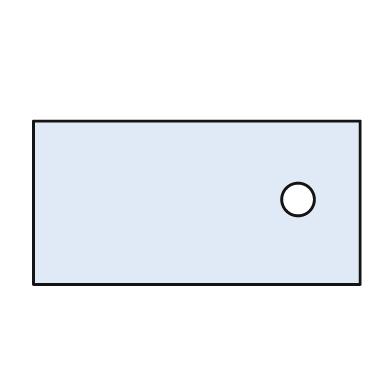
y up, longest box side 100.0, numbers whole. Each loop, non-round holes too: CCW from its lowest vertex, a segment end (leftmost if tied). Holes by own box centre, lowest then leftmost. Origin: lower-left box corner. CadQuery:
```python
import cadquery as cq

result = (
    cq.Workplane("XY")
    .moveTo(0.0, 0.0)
    .lineTo(100.0, 0.0)
    .lineTo(100.0, 50.0)
    .lineTo(0.0, 50.0)
    .close()
    .moveTo(81.0, 26.0)
    .circle(5.0)
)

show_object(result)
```